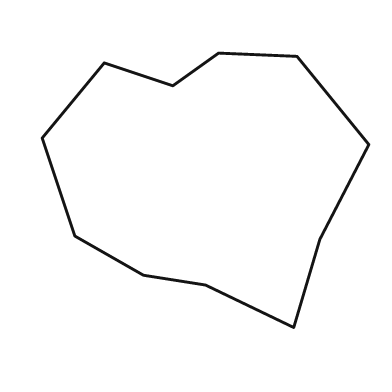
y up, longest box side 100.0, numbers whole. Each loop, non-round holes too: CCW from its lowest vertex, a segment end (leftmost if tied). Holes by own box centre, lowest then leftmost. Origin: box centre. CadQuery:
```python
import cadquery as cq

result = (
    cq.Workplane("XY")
    .moveTo(27.0, -42.0)
    .lineTo(35.0, -15.0)
    .lineTo(50.0, 14.0)
    .lineTo(28.0, 41.0)
    .lineTo(4.0, 42.0)
    .lineTo(-10.0, 32.0)
    .lineTo(-31.0, 39.0)
    .lineTo(-50.0, 16.0)
    .lineTo(-40.0, -14.0)
    .lineTo(-19.0, -26.0)
    .lineTo(0.0, -29.0)
    .close()
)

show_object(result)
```